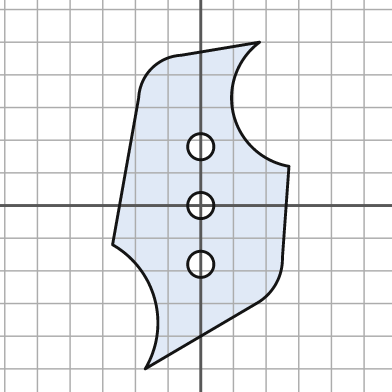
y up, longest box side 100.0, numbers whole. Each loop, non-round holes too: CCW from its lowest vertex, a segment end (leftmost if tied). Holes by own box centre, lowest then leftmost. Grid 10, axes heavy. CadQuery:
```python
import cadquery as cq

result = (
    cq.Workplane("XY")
    .moveTo(-17.0, -50.0)
    .lineTo(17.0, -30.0)
    .threePointArc((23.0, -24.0), (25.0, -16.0))
    .lineTo(27.0, 12.0)
    .threePointArc((10.0, 28.0), (18.0, 50.0))
    .lineTo(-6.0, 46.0)
    .threePointArc((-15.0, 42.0), (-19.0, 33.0))
    .lineTo(-27.0, -12.0)
    .threePointArc((-14.0, -29.0), (-17.0, -50.0))
    .close()
    .moveTo(0.0, -18.0)
    .circle(4.0)
    .moveTo(0.0, 0.0)
    .circle(4.0)
    .moveTo(0.0, 18.0)
    .circle(4.0)
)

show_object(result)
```